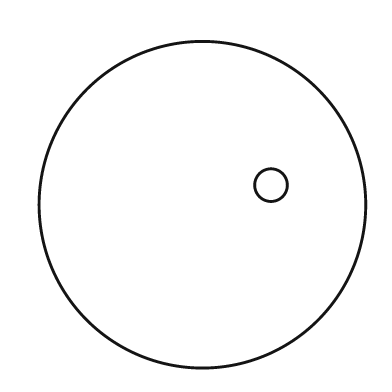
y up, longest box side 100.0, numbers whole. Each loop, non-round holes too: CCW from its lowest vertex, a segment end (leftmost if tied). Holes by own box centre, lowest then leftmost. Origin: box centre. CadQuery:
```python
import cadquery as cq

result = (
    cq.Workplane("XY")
    .moveTo(0.0, 0.0)
    .circle(50.0)
    .moveTo(21.0, 6.0)
    .circle(5.0)
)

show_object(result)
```